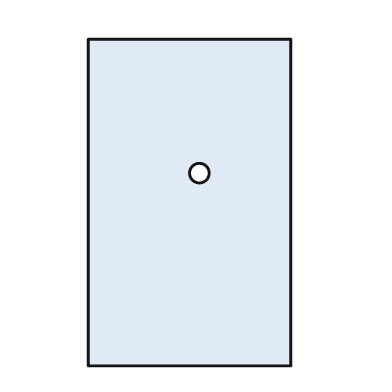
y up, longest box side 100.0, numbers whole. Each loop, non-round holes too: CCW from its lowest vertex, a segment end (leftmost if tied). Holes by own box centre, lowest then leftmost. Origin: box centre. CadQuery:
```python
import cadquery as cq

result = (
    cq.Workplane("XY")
    .moveTo(-31.0, -50.0)
    .lineTo(31.0, -50.0)
    .lineTo(31.0, 50.0)
    .lineTo(-31.0, 50.0)
    .close()
    .moveTo(3.0, 9.0)
    .circle(3.0)
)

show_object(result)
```